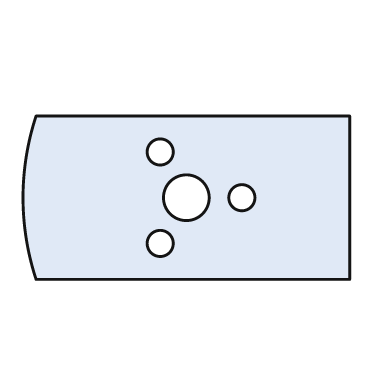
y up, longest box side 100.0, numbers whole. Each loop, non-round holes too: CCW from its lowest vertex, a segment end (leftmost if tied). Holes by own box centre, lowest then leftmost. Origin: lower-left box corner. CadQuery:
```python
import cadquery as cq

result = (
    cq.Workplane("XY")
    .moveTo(4.0, 0.0)
    .lineTo(100.0, 0.0)
    .lineTo(100.0, 50.0)
    .lineTo(4.0, 50.0)
    .threePointArc((0.0, 25.0), (4.0, 0.0))
    .close()
    .moveTo(42.0, 11.0)
    .circle(4.0)
    .moveTo(50.0, 25.0)
    .circle(7.0)
    .moveTo(67.0, 25.0)
    .circle(4.0)
    .moveTo(42.0, 39.0)
    .circle(4.0)
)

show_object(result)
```